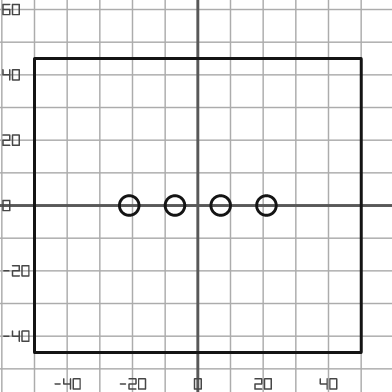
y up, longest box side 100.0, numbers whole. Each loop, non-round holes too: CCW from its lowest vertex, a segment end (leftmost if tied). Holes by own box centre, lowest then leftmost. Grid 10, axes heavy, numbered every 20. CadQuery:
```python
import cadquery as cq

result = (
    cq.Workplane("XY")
    .moveTo(-50.0, -45.0)
    .lineTo(50.0, -45.0)
    .lineTo(50.0, 45.0)
    .lineTo(-50.0, 45.0)
    .close()
    .moveTo(-21.0, 0.0)
    .circle(3.0)
    .moveTo(-7.0, 0.0)
    .circle(3.0)
    .moveTo(7.0, 0.0)
    .circle(3.0)
    .moveTo(21.0, 0.0)
    .circle(3.0)
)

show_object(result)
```